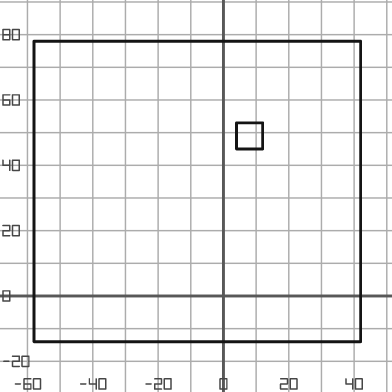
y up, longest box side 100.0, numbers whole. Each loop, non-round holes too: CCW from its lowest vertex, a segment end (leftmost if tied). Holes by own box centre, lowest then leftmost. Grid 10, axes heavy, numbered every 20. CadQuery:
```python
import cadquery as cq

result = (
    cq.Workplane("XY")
    .moveTo(-58.0, -14.0)
    .lineTo(42.0, -14.0)
    .lineTo(42.0, 78.0)
    .lineTo(-58.0, 78.0)
    .close()
    .moveTo(4.0, 45.0)
    .lineTo(12.0, 45.0)
    .lineTo(12.0, 53.0)
    .lineTo(4.0, 53.0)
    .close()
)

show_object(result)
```